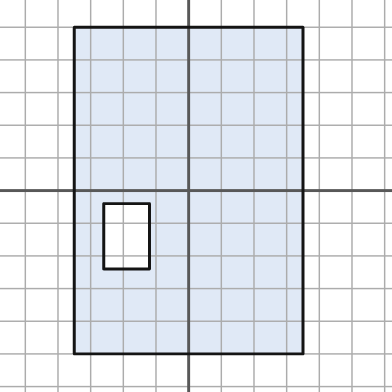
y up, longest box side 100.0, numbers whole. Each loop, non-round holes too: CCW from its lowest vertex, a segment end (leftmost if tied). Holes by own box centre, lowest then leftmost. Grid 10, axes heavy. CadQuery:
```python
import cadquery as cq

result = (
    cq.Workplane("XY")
    .moveTo(-35.0, -50.0)
    .lineTo(35.0, -50.0)
    .lineTo(35.0, 50.0)
    .lineTo(-35.0, 50.0)
    .close()
    .moveTo(-26.0, -24.0)
    .lineTo(-12.0, -24.0)
    .lineTo(-12.0, -4.0)
    .lineTo(-26.0, -4.0)
    .close()
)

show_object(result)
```